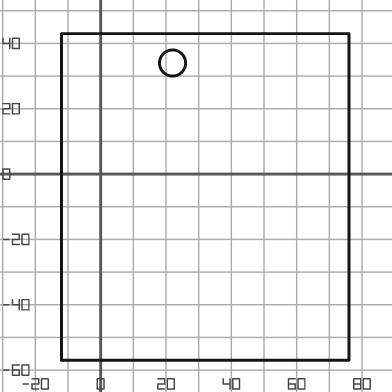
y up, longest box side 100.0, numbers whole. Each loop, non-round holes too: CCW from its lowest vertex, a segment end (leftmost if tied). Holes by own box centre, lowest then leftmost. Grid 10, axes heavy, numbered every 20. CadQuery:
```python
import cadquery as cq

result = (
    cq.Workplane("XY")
    .moveTo(-12.0, -57.0)
    .lineTo(76.0, -57.0)
    .lineTo(76.0, 43.0)
    .lineTo(-12.0, 43.0)
    .close()
    .moveTo(22.0, 34.0)
    .circle(4.0)
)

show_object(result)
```